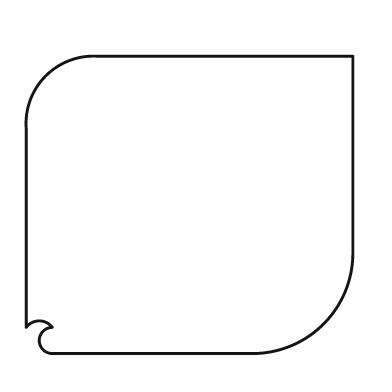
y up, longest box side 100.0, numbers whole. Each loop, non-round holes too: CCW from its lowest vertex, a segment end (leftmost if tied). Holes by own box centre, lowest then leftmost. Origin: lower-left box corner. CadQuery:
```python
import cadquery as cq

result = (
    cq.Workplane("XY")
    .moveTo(8.0, 0.0)
    .lineTo(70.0, 0.0)
    .threePointArc((91.0, 9.0), (100.0, 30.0))
    .lineTo(100.0, 91.0)
    .lineTo(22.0, 91.0)
    .threePointArc((6.0, 85.0), (0.0, 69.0))
    .lineTo(0.0, 8.0)
    .threePointArc((4.0, 10.0), (8.0, 8.0))
    .threePointArc((4.0, 4.0), (8.0, 0.0))
    .close()
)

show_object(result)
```